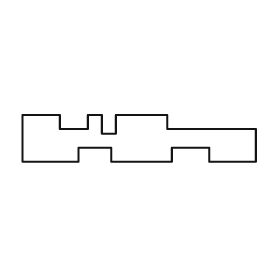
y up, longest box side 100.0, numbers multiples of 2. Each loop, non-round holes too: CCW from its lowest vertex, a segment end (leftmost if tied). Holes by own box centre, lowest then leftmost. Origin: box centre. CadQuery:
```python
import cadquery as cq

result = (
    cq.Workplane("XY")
    .moveTo(-50.0, -10.0)
    .lineTo(-26.0, -10.0)
    .lineTo(-26.0, -4.0)
    .lineTo(-12.0, -4.0)
    .lineTo(-12.0, -10.0)
    .lineTo(14.0, -10.0)
    .lineTo(14.0, -4.0)
    .lineTo(30.0, -4.0)
    .lineTo(30.0, -10.0)
    .lineTo(50.0, -10.0)
    .lineTo(50.0, 4.0)
    .lineTo(12.0, 4.0)
    .lineTo(12.0, 10.0)
    .lineTo(-10.0, 10.0)
    .lineTo(-10.0, 2.0)
    .lineTo(-16.0, 2.0)
    .lineTo(-16.0, 10.0)
    .lineTo(-22.0, 10.0)
    .lineTo(-22.0, 4.0)
    .lineTo(-34.0, 4.0)
    .lineTo(-34.0, 10.0)
    .lineTo(-50.0, 10.0)
    .close()
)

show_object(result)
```